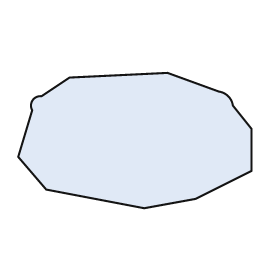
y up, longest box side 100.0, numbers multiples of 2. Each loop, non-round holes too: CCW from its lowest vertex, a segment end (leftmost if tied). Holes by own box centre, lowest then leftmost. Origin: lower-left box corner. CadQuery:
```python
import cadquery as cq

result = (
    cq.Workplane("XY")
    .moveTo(54.0, 0.0)
    .lineTo(76.0, 4.0)
    .lineTo(100.0, 16.0)
    .lineTo(100.0, 34.0)
    .lineTo(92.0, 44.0)
    .threePointArc((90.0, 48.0), (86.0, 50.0))
    .lineTo(64.0, 58.0)
    .lineTo(22.0, 56.0)
    .lineTo(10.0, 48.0)
    .threePointArc((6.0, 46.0), (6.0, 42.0))
    .lineTo(0.0, 22.0)
    .lineTo(12.0, 8.0)
    .close()
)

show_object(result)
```